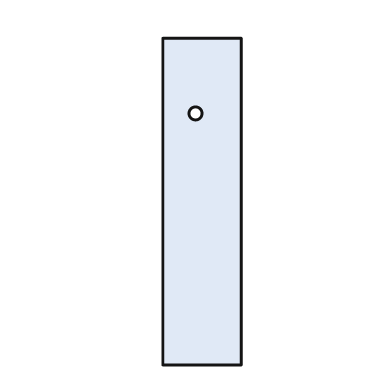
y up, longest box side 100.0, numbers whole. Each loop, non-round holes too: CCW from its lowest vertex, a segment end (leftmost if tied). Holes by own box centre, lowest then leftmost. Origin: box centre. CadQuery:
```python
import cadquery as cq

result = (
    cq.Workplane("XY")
    .moveTo(-12.0, -50.0)
    .lineTo(12.0, -50.0)
    .lineTo(12.0, 50.0)
    .lineTo(-12.0, 50.0)
    .close()
    .moveTo(-2.0, 27.0)
    .circle(2.0)
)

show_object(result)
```